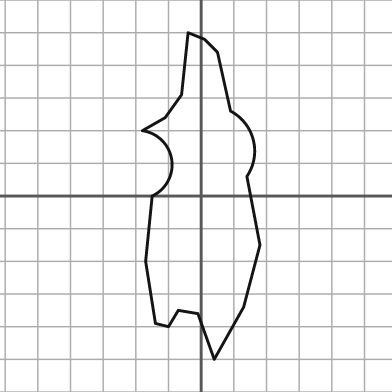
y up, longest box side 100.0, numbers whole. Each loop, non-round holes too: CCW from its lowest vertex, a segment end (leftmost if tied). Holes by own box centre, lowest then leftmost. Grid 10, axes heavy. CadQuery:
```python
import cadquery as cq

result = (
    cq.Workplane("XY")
    .moveTo(4.0, -50.0)
    .lineTo(13.0, -34.0)
    .lineTo(18.0, -15.0)
    .lineTo(14.0, 6.0)
    .threePointArc((16.0, 17.0), (9.0, 26.0))
    .lineTo(5.0, 44.0)
    .lineTo(1.0, 48.0)
    .lineTo(-4.0, 50.0)
    .lineTo(-6.0, 31.0)
    .lineTo(-11.0, 24.0)
    .lineTo(-18.0, 20.0)
    .threePointArc((-9.0, 11.0), (-15.0, 0.0))
    .lineTo(-17.0, -20.0)
    .lineTo(-14.0, -39.0)
    .lineTo(-10.0, -40.0)
    .lineTo(-7.0, -35.0)
    .lineTo(-1.0, -36.0)
    .close()
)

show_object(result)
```